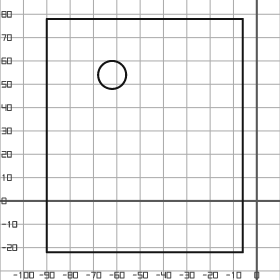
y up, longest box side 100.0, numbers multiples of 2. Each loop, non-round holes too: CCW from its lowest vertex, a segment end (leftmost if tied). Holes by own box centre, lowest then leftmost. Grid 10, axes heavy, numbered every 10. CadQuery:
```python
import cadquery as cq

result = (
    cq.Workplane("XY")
    .moveTo(-90.0, -22.0)
    .lineTo(-6.0, -22.0)
    .lineTo(-6.0, 78.0)
    .lineTo(-90.0, 78.0)
    .close()
    .moveTo(-62.0, 54.0)
    .circle(6.0)
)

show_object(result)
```